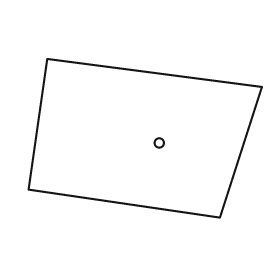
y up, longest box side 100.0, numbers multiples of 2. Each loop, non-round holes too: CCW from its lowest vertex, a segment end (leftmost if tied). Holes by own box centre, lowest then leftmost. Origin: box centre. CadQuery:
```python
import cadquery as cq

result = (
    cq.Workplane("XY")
    .moveTo(32.0, -34.0)
    .lineTo(50.0, 22.0)
    .lineTo(-42.0, 34.0)
    .lineTo(-50.0, -22.0)
    .close()
    .moveTo(6.0, -2.0)
    .circle(2.0)
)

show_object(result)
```